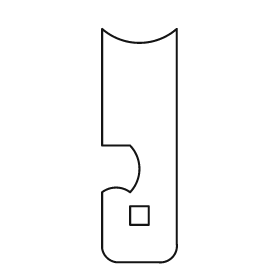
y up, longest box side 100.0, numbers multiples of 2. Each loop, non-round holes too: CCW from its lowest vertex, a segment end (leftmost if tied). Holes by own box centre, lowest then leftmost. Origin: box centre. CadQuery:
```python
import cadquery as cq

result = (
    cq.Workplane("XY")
    .moveTo(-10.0, -50.0)
    .lineTo(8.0, -50.0)
    .threePointArc((14.0, -48.0), (16.0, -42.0))
    .lineTo(16.0, 50.0)
    .threePointArc((0.0, 44.0), (-16.0, 50.0))
    .lineTo(-16.0, 0.0)
    .lineTo(-4.0, 0.0)
    .threePointArc((0.0, -10.0), (-4.0, -20.0))
    .threePointArc((-10.0, -18.0), (-16.0, -20.0))
    .lineTo(-16.0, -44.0)
    .threePointArc((-14.0, -48.0), (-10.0, -50.0))
    .close()
    .moveTo(-4.0, -34.0)
    .lineTo(4.0, -34.0)
    .lineTo(4.0, -26.0)
    .lineTo(-4.0, -26.0)
    .close()
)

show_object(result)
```